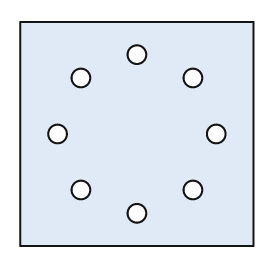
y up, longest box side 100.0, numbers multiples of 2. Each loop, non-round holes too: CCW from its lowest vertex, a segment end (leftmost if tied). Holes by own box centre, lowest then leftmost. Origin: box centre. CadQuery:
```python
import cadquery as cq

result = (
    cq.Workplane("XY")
    .moveTo(-50.0, -48.0)
    .lineTo(50.0, -48.0)
    .lineTo(50.0, 48.0)
    .lineTo(-50.0, 48.0)
    .close()
    .moveTo(0.0, -34.0)
    .circle(4.0)
    .moveTo(-24.0, -24.0)
    .circle(4.0)
    .moveTo(24.0, -24.0)
    .circle(4.0)
    .moveTo(-34.0, 0.0)
    .circle(4.0)
    .moveTo(34.0, 0.0)
    .circle(4.0)
    .moveTo(-24.0, 24.0)
    .circle(4.0)
    .moveTo(24.0, 24.0)
    .circle(4.0)
    .moveTo(0.0, 34.0)
    .circle(4.0)
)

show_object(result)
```